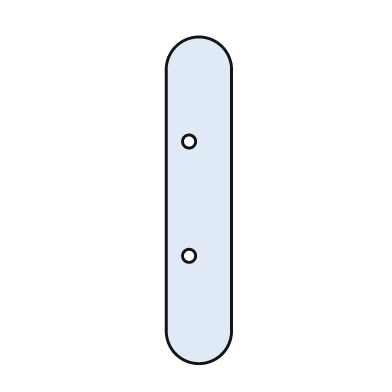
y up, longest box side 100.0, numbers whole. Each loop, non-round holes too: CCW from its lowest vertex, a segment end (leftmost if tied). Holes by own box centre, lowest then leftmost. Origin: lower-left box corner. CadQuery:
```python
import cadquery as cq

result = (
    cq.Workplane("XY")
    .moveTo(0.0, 10.0)
    .threePointArc((10.0, 0.0), (20.0, 10.0))
    .lineTo(20.0, 90.0)
    .threePointArc((10.0, 100.0), (0.0, 90.0))
    .close()
    .moveTo(7.0, 33.0)
    .circle(2.0)
    .moveTo(7.0, 68.0)
    .circle(2.0)
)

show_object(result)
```